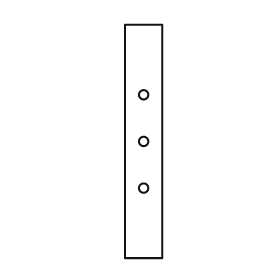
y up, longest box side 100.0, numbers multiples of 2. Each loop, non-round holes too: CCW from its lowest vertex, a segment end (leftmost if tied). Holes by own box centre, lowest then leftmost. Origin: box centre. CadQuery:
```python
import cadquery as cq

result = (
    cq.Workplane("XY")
    .moveTo(-8.0, -50.0)
    .lineTo(8.0, -50.0)
    .lineTo(8.0, 50.0)
    .lineTo(-8.0, 50.0)
    .close()
    .moveTo(0.0, -20.0)
    .circle(2.0)
    .moveTo(0.0, 0.0)
    .circle(2.0)
    .moveTo(0.0, 20.0)
    .circle(2.0)
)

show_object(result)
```